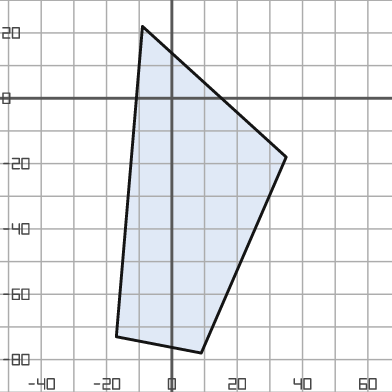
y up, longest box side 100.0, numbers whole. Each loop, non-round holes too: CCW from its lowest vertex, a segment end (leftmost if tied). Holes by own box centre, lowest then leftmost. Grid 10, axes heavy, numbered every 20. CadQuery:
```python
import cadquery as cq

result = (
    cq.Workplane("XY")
    .moveTo(9.0, -78.0)
    .lineTo(35.0, -18.0)
    .lineTo(-9.0, 22.0)
    .lineTo(-17.0, -73.0)
    .close()
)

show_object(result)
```